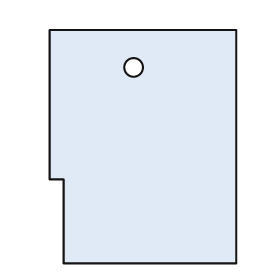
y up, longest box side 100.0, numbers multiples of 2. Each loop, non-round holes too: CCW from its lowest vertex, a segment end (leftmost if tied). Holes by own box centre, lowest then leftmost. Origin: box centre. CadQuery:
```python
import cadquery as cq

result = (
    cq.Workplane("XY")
    .moveTo(-34.0, -50.0)
    .lineTo(40.0, -50.0)
    .lineTo(40.0, 50.0)
    .lineTo(-40.0, 50.0)
    .lineTo(-40.0, -14.0)
    .lineTo(-34.0, -14.0)
    .close()
    .moveTo(-4.0, 34.0)
    .circle(4.0)
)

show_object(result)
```